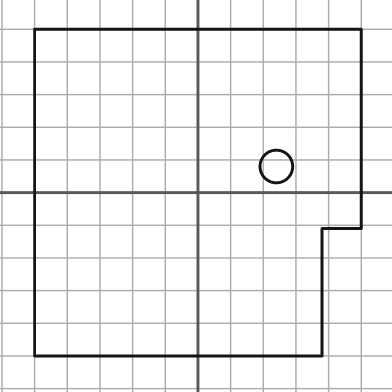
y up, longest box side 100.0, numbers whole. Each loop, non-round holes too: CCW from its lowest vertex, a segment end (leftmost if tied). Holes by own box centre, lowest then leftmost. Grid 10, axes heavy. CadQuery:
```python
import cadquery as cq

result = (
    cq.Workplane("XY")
    .moveTo(-50.0, -50.0)
    .lineTo(38.0, -50.0)
    .lineTo(38.0, -11.0)
    .lineTo(50.0, -11.0)
    .lineTo(50.0, 50.0)
    .lineTo(-50.0, 50.0)
    .close()
    .moveTo(24.0, 8.0)
    .circle(5.0)
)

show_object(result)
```